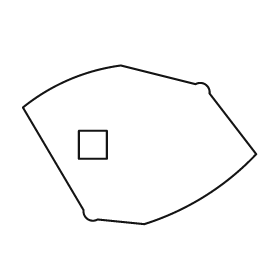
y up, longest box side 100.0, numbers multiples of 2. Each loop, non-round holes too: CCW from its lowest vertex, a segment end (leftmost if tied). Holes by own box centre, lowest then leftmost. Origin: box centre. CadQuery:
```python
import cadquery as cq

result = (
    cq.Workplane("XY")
    .moveTo(2.0, -34.0)
    .threePointArc((28.0, -22.0), (50.0, -4.0))
    .lineTo(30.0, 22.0)
    .threePointArc((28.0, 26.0), (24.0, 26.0))
    .lineTo(-8.0, 34.0)
    .threePointArc((-30.0, 28.0), (-50.0, 16.0))
    .lineTo(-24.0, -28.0)
    .threePointArc((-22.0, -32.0), (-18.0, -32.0))
    .close()
    .moveTo(-26.0, -6.0)
    .lineTo(-14.0, -6.0)
    .lineTo(-14.0, 6.0)
    .lineTo(-26.0, 6.0)
    .close()
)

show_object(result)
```